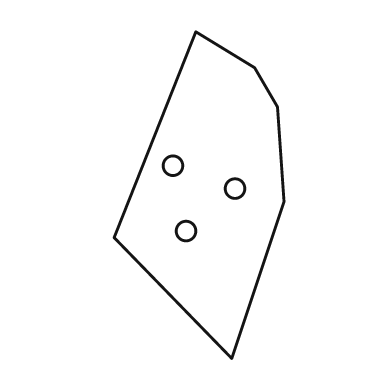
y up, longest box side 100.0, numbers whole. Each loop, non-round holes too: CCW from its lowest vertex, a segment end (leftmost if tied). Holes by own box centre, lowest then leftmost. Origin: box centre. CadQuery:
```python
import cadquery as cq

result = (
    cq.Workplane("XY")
    .moveTo(10.0, -50.0)
    .lineTo(26.0, -2.0)
    .lineTo(24.0, 27.0)
    .lineTo(17.0, 39.0)
    .lineTo(-1.0, 50.0)
    .lineTo(-26.0, -13.0)
    .close()
    .moveTo(-4.0, -11.0)
    .circle(3.0)
    .moveTo(11.0, 2.0)
    .circle(3.0)
    .moveTo(-8.0, 9.0)
    .circle(3.0)
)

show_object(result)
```